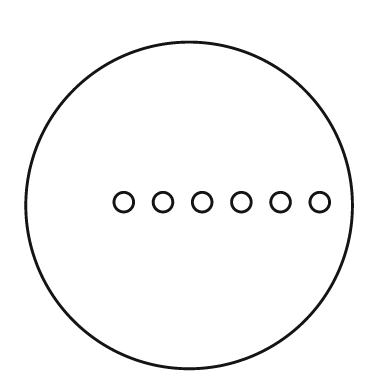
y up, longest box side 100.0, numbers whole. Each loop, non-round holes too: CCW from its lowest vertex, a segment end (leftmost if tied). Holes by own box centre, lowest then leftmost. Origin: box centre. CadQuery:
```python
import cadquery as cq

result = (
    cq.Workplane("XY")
    .moveTo(0.0, 0.0)
    .circle(50.0)
    .moveTo(-20.0, 1.0)
    .circle(3.0)
    .moveTo(-8.0, 1.0)
    .circle(3.0)
    .moveTo(4.0, 1.0)
    .circle(3.0)
    .moveTo(16.0, 1.0)
    .circle(3.0)
    .moveTo(28.0, 1.0)
    .circle(3.0)
    .moveTo(40.0, 1.0)
    .circle(3.0)
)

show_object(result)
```